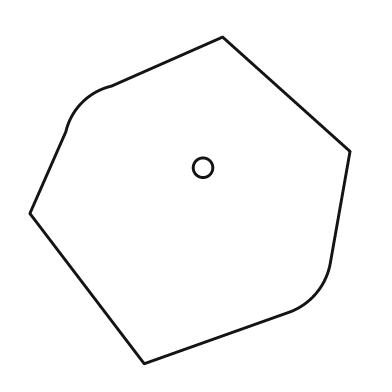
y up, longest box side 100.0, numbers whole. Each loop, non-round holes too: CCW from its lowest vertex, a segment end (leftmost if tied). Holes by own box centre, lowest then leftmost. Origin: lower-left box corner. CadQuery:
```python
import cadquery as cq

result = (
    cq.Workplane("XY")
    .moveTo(35.0, 0.0)
    .lineTo(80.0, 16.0)
    .threePointArc((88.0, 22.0), (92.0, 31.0))
    .lineTo(98.0, 65.0)
    .lineTo(59.0, 100.0)
    .lineTo(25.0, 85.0)
    .threePointArc((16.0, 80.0), (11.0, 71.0))
    .lineTo(0.0, 46.0)
    .close()
    .moveTo(53.0, 60.0)
    .circle(3.0)
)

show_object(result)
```